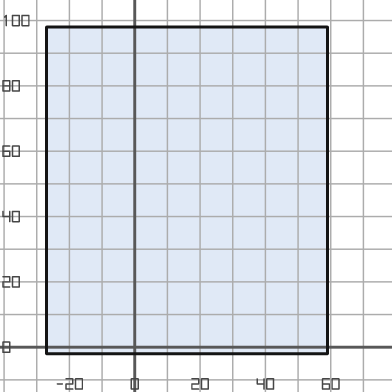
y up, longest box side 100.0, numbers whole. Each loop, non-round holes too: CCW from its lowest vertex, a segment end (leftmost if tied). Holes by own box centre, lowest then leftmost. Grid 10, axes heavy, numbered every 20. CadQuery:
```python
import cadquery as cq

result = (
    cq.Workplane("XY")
    .moveTo(-27.0, -2.0)
    .lineTo(59.0, -2.0)
    .lineTo(59.0, 98.0)
    .lineTo(-27.0, 98.0)
    .close()
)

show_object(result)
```